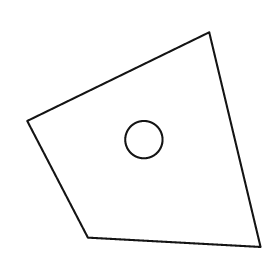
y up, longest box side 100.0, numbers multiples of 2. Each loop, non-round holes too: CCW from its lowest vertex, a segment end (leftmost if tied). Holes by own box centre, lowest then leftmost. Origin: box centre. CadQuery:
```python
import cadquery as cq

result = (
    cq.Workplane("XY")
    .moveTo(50.0, -46.0)
    .lineTo(28.0, 46.0)
    .lineTo(-50.0, 8.0)
    .lineTo(-24.0, -42.0)
    .close()
    .moveTo(0.0, 0.0)
    .circle(8.0)
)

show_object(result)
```